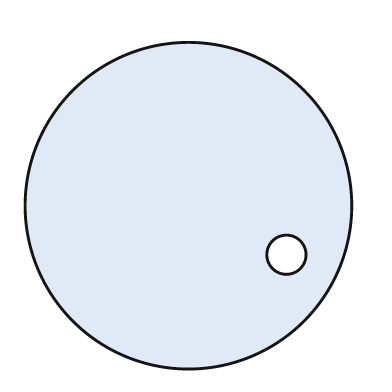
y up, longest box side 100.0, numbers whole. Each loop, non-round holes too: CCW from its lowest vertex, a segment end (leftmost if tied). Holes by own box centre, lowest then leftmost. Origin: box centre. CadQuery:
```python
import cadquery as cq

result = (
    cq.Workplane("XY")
    .moveTo(0.0, 0.0)
    .circle(50.0)
    .moveTo(30.0, -15.0)
    .circle(6.0)
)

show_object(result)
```